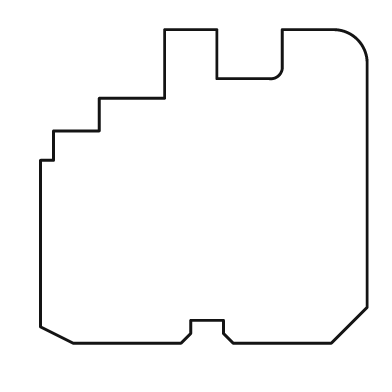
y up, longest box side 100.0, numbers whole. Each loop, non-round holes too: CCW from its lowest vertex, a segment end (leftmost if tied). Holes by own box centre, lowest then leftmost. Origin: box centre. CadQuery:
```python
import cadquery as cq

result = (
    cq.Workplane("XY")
    .moveTo(-40.0, -48.0)
    .lineTo(-7.0, -48.0)
    .lineTo(-4.0, -45.0)
    .lineTo(-4.0, -41.0)
    .lineTo(6.0, -41.0)
    .lineTo(6.0, -45.0)
    .lineTo(9.0, -48.0)
    .lineTo(39.0, -48.0)
    .lineTo(50.0, -37.0)
    .lineTo(50.0, 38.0)
    .threePointArc((47.0, 45.0), (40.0, 48.0))
    .lineTo(24.0, 48.0)
    .lineTo(24.0, 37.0)
    .threePointArc((23.0, 34.0), (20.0, 33.0))
    .lineTo(4.0, 33.0)
    .lineTo(4.0, 48.0)
    .lineTo(-12.0, 48.0)
    .lineTo(-12.0, 27.0)
    .lineTo(-32.0, 27.0)
    .lineTo(-32.0, 17.0)
    .lineTo(-46.0, 17.0)
    .lineTo(-46.0, 8.0)
    .lineTo(-50.0, 8.0)
    .lineTo(-50.0, -43.0)
    .close()
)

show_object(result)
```